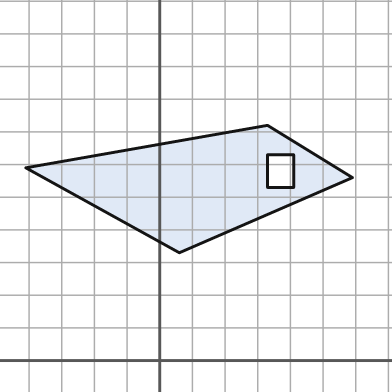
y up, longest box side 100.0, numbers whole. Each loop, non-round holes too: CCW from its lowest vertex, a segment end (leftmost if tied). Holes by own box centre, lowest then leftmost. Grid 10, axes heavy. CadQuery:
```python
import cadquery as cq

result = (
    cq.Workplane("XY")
    .moveTo(6.0, 33.0)
    .lineTo(59.0, 56.0)
    .lineTo(33.0, 72.0)
    .lineTo(-41.0, 59.0)
    .close()
    .moveTo(33.0, 53.0)
    .lineTo(41.0, 53.0)
    .lineTo(41.0, 63.0)
    .lineTo(33.0, 63.0)
    .close()
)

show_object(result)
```